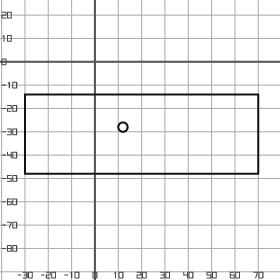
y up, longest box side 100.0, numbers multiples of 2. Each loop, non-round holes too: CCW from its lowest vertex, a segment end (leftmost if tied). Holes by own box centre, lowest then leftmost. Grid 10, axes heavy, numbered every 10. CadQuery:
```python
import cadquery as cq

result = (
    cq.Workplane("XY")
    .moveTo(-30.0, -48.0)
    .lineTo(70.0, -48.0)
    .lineTo(70.0, -14.0)
    .lineTo(-30.0, -14.0)
    .close()
    .moveTo(12.0, -28.0)
    .circle(2.0)
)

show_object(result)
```